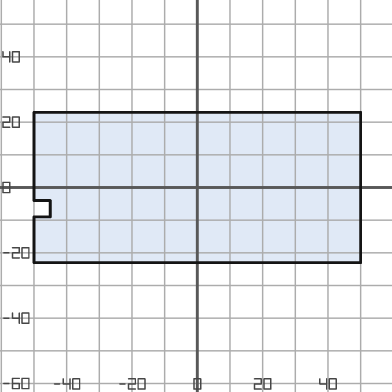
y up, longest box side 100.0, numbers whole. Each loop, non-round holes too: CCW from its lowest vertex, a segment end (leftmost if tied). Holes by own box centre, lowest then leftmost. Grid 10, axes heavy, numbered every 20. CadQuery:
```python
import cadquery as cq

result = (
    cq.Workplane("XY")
    .moveTo(-50.0, -23.0)
    .lineTo(50.0, -23.0)
    .lineTo(50.0, 23.0)
    .lineTo(-50.0, 23.0)
    .lineTo(-50.0, -4.0)
    .lineTo(-45.0, -4.0)
    .lineTo(-45.0, -9.0)
    .lineTo(-50.0, -9.0)
    .close()
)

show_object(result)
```